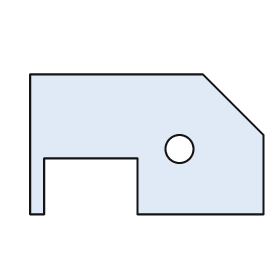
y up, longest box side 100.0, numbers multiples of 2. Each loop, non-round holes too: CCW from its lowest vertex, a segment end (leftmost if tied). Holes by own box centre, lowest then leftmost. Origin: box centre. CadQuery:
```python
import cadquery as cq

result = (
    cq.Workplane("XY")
    .moveTo(-50.0, -30.0)
    .lineTo(-44.0, -30.0)
    .lineTo(-44.0, -6.0)
    .lineTo(-4.0, -6.0)
    .lineTo(-4.0, -30.0)
    .lineTo(50.0, -30.0)
    .lineTo(50.0, 4.0)
    .lineTo(24.0, 30.0)
    .lineTo(-50.0, 30.0)
    .close()
    .moveTo(14.0, -2.0)
    .circle(6.0)
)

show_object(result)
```